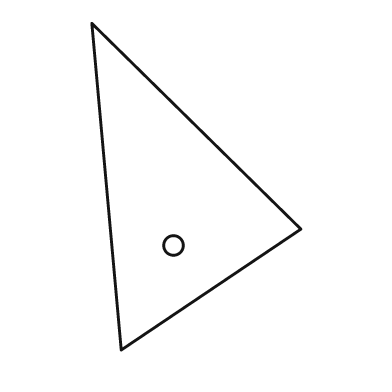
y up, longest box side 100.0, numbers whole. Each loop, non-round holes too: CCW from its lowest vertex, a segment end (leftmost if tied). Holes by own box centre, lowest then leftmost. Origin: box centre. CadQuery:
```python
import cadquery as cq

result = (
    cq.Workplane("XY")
    .moveTo(-23.0, -50.0)
    .lineTo(32.0, -13.0)
    .lineTo(-32.0, 50.0)
    .close()
    .moveTo(-7.0, -18.0)
    .circle(3.0)
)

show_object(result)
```